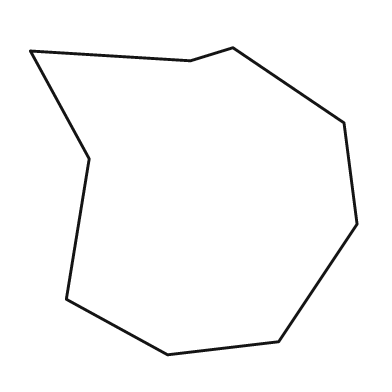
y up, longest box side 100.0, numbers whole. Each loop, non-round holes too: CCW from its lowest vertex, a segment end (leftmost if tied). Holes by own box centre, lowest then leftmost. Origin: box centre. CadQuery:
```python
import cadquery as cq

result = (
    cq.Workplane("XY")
    .moveTo(-8.0, -47.0)
    .lineTo(26.0, -43.0)
    .lineTo(50.0, -7.0)
    .lineTo(46.0, 24.0)
    .lineTo(12.0, 47.0)
    .lineTo(-1.0, 43.0)
    .lineTo(-50.0, 46.0)
    .lineTo(-32.0, 13.0)
    .lineTo(-39.0, -30.0)
    .close()
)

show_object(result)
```